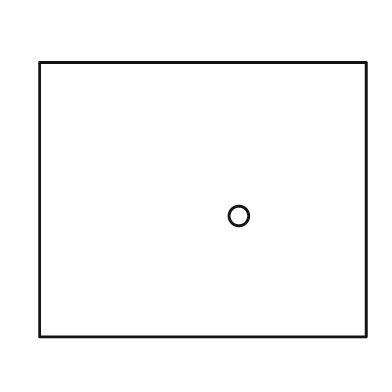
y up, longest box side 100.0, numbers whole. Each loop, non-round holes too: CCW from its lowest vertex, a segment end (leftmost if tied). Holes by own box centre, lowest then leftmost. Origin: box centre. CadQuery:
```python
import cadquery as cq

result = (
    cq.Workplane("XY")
    .moveTo(-50.0, -42.0)
    .lineTo(50.0, -42.0)
    .lineTo(50.0, 42.0)
    .lineTo(-50.0, 42.0)
    .close()
    .moveTo(11.0, -5.0)
    .circle(3.0)
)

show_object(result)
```